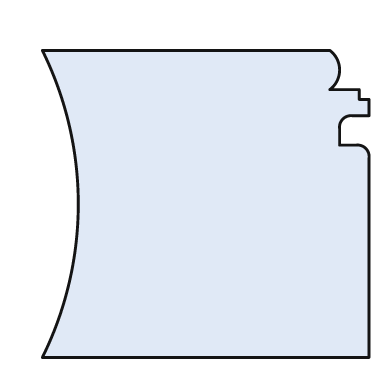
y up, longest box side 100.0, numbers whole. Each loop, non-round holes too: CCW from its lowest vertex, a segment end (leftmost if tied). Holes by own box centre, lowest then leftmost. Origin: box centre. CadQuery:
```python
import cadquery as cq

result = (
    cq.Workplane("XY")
    .moveTo(-50.0, -47.0)
    .lineTo(50.0, -47.0)
    .lineTo(50.0, 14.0)
    .threePointArc((49.0, 17.0), (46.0, 18.0))
    .lineTo(41.0, 18.0)
    .lineTo(41.0, 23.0)
    .threePointArc((42.0, 26.0), (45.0, 27.0))
    .lineTo(50.0, 27.0)
    .lineTo(50.0, 32.0)
    .lineTo(47.0, 32.0)
    .lineTo(47.0, 35.0)
    .lineTo(38.0, 35.0)
    .threePointArc((41.0, 41.0), (38.0, 47.0))
    .lineTo(-50.0, 47.0)
    .threePointArc((-39.0, 0.0), (-50.0, -47.0))
    .close()
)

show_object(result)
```